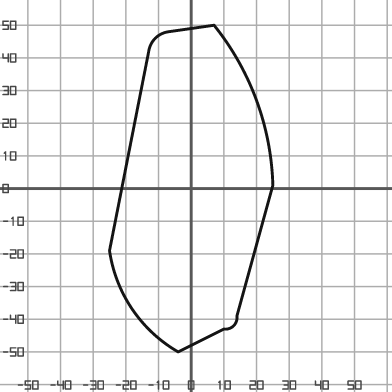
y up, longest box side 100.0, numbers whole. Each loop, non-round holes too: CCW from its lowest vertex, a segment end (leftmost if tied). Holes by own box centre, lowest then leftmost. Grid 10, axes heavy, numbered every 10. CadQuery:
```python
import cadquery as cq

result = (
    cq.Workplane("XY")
    .moveTo(-4.0, -50.0)
    .lineTo(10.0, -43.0)
    .threePointArc((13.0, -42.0), (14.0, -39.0))
    .lineTo(25.0, 1.0)
    .threePointArc((20.0, 27.0), (7.0, 50.0))
    .lineTo(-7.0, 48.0)
    .threePointArc((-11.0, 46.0), (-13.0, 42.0))
    .lineTo(-25.0, -19.0)
    .threePointArc((-18.0, -37.0), (-4.0, -50.0))
    .close()
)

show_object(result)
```